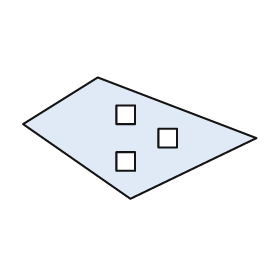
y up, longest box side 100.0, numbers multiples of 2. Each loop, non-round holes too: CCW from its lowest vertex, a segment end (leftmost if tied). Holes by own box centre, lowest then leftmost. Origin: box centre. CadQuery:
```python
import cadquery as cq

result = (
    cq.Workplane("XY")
    .moveTo(-4.0, -26.0)
    .lineTo(50.0, 0.0)
    .lineTo(-18.0, 26.0)
    .lineTo(-50.0, 6.0)
    .close()
    .moveTo(-10.0, -14.0)
    .lineTo(-2.0, -14.0)
    .lineTo(-2.0, -6.0)
    .lineTo(-10.0, -6.0)
    .close()
    .moveTo(8.0, -4.0)
    .lineTo(16.0, -4.0)
    .lineTo(16.0, 4.0)
    .lineTo(8.0, 4.0)
    .close()
    .moveTo(-10.0, 6.0)
    .lineTo(-2.0, 6.0)
    .lineTo(-2.0, 14.0)
    .lineTo(-10.0, 14.0)
    .close()
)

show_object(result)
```